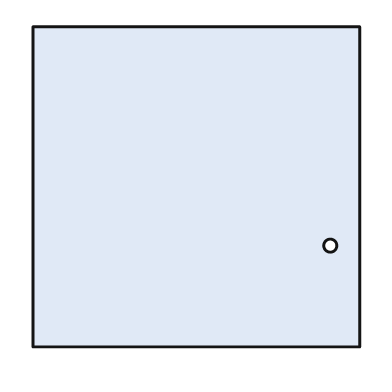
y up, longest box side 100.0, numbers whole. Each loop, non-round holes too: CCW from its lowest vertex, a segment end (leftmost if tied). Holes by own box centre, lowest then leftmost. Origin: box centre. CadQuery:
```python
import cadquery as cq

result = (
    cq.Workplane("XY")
    .moveTo(-50.0, -49.0)
    .lineTo(50.0, -49.0)
    .lineTo(50.0, 49.0)
    .lineTo(-50.0, 49.0)
    .close()
    .moveTo(41.0, -18.0)
    .circle(2.0)
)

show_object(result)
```